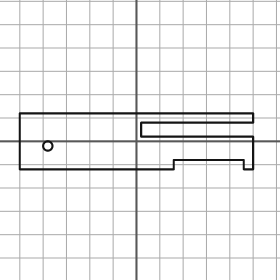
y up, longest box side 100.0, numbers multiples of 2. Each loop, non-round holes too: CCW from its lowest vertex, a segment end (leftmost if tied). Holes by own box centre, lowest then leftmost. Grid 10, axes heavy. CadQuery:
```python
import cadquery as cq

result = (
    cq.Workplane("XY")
    .moveTo(-50.0, -12.0)
    .lineTo(16.0, -12.0)
    .lineTo(16.0, -8.0)
    .lineTo(46.0, -8.0)
    .lineTo(46.0, -12.0)
    .lineTo(50.0, -12.0)
    .lineTo(50.0, 2.0)
    .lineTo(2.0, 2.0)
    .lineTo(2.0, 8.0)
    .lineTo(50.0, 8.0)
    .lineTo(50.0, 12.0)
    .lineTo(-50.0, 12.0)
    .close()
    .moveTo(-38.0, -2.0)
    .circle(2.0)
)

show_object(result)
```